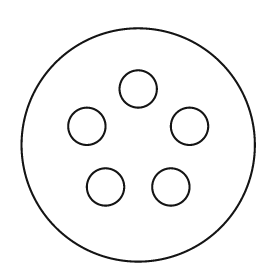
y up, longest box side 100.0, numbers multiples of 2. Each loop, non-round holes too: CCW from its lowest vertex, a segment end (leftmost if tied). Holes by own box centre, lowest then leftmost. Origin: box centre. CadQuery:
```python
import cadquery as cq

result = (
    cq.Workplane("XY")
    .moveTo(0.0, 0.0)
    .circle(50.0)
    .moveTo(-14.0, -18.0)
    .circle(8.0)
    .moveTo(14.0, -18.0)
    .circle(8.0)
    .moveTo(-22.0, 8.0)
    .circle(8.0)
    .moveTo(22.0, 8.0)
    .circle(8.0)
    .moveTo(0.0, 24.0)
    .circle(8.0)
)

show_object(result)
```